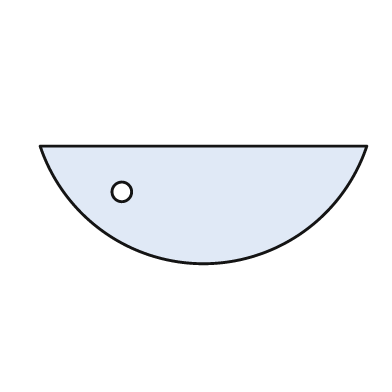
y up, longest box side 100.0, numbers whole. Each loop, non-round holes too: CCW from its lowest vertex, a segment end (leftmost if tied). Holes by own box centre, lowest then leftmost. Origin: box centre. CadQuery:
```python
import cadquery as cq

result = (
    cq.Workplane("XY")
    .moveTo(-50.0, 18.0)
    .threePointArc((0.0, -18.0), (50.0, 18.0))
    .close()
    .moveTo(-25.0, 4.0)
    .circle(3.0)
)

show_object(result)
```